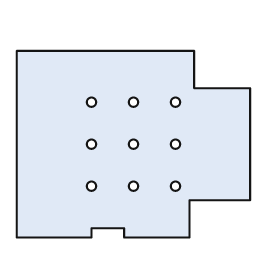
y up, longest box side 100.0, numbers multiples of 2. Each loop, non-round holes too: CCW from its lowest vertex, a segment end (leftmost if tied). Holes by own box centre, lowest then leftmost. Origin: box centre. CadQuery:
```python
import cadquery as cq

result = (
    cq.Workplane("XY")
    .moveTo(-50.0, -40.0)
    .lineTo(-18.0, -40.0)
    .lineTo(-18.0, -36.0)
    .lineTo(-4.0, -36.0)
    .lineTo(-4.0, -40.0)
    .lineTo(24.0, -40.0)
    .lineTo(24.0, -24.0)
    .lineTo(50.0, -24.0)
    .lineTo(50.0, 24.0)
    .lineTo(26.0, 24.0)
    .lineTo(26.0, 40.0)
    .lineTo(-50.0, 40.0)
    .close()
    .moveTo(-18.0, -18.0)
    .circle(2.0)
    .moveTo(0.0, -18.0)
    .circle(2.0)
    .moveTo(18.0, -18.0)
    .circle(2.0)
    .moveTo(-18.0, 0.0)
    .circle(2.0)
    .moveTo(0.0, 0.0)
    .circle(2.0)
    .moveTo(18.0, 0.0)
    .circle(2.0)
    .moveTo(-18.0, 18.0)
    .circle(2.0)
    .moveTo(0.0, 18.0)
    .circle(2.0)
    .moveTo(18.0, 18.0)
    .circle(2.0)
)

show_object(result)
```